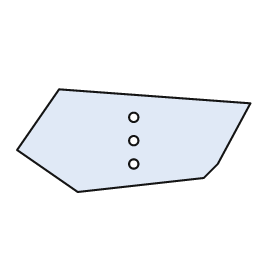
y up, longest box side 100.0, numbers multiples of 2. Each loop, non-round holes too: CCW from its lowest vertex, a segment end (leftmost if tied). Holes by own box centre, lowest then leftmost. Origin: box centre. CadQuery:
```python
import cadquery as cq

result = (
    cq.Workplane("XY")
    .moveTo(-24.0, -22.0)
    .lineTo(30.0, -16.0)
    .lineTo(36.0, -10.0)
    .lineTo(50.0, 16.0)
    .lineTo(-32.0, 22.0)
    .lineTo(-50.0, -4.0)
    .close()
    .moveTo(0.0, -10.0)
    .circle(2.0)
    .moveTo(0.0, 0.0)
    .circle(2.0)
    .moveTo(0.0, 10.0)
    .circle(2.0)
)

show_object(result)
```